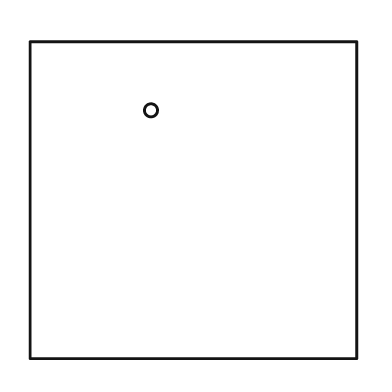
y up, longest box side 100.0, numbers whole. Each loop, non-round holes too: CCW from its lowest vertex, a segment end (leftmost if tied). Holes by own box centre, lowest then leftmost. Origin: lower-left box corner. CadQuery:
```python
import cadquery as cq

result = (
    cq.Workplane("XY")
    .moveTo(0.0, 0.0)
    .lineTo(100.0, 0.0)
    .lineTo(100.0, 97.0)
    .lineTo(0.0, 97.0)
    .close()
    .moveTo(37.0, 76.0)
    .circle(2.0)
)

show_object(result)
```